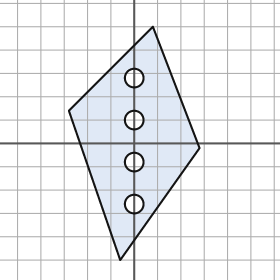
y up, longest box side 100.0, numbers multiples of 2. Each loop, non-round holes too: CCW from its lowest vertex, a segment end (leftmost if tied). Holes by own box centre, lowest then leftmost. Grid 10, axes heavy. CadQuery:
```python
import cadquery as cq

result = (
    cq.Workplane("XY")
    .moveTo(-6.0, -50.0)
    .lineTo(28.0, -2.0)
    .lineTo(8.0, 50.0)
    .lineTo(-28.0, 14.0)
    .close()
    .moveTo(0.0, -26.0)
    .circle(4.0)
    .moveTo(0.0, -8.0)
    .circle(4.0)
    .moveTo(0.0, 10.0)
    .circle(4.0)
    .moveTo(0.0, 28.0)
    .circle(4.0)
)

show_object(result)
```